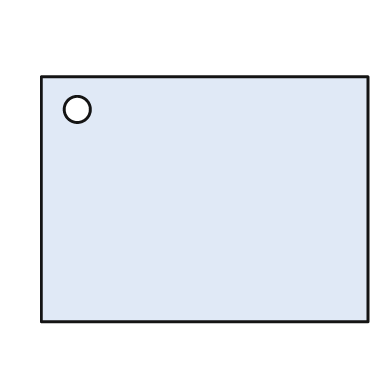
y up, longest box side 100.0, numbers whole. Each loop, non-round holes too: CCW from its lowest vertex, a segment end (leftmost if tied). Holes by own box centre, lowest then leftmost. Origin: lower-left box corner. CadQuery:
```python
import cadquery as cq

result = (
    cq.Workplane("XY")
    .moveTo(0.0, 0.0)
    .lineTo(100.0, 0.0)
    .lineTo(100.0, 75.0)
    .lineTo(0.0, 75.0)
    .close()
    .moveTo(11.0, 65.0)
    .circle(4.0)
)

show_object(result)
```